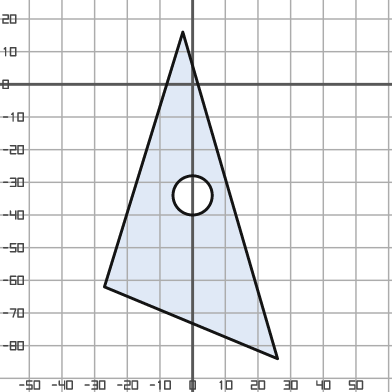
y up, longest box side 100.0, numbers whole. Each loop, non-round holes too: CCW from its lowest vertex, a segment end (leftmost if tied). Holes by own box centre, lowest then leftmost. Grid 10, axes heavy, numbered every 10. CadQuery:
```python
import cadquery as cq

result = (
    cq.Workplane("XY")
    .moveTo(26.0, -84.0)
    .lineTo(-3.0, 16.0)
    .lineTo(-27.0, -62.0)
    .close()
    .moveTo(0.0, -34.0)
    .circle(6.0)
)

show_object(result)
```